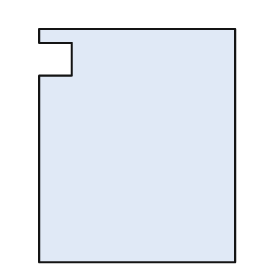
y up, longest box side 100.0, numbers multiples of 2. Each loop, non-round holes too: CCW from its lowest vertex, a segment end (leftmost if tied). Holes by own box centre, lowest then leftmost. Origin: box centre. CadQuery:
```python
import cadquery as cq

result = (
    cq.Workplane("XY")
    .moveTo(-42.0, -50.0)
    .lineTo(42.0, -50.0)
    .lineTo(42.0, 50.0)
    .lineTo(-42.0, 50.0)
    .lineTo(-42.0, 44.0)
    .lineTo(-28.0, 44.0)
    .lineTo(-28.0, 30.0)
    .lineTo(-42.0, 30.0)
    .close()
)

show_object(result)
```